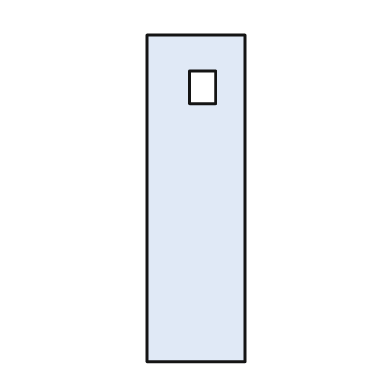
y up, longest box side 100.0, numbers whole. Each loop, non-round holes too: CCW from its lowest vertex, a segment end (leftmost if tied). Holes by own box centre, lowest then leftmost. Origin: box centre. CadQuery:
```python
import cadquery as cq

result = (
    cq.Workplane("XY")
    .moveTo(-15.0, -50.0)
    .lineTo(15.0, -50.0)
    .lineTo(15.0, 50.0)
    .lineTo(-15.0, 50.0)
    .close()
    .moveTo(-2.0, 29.0)
    .lineTo(6.0, 29.0)
    .lineTo(6.0, 39.0)
    .lineTo(-2.0, 39.0)
    .close()
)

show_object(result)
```